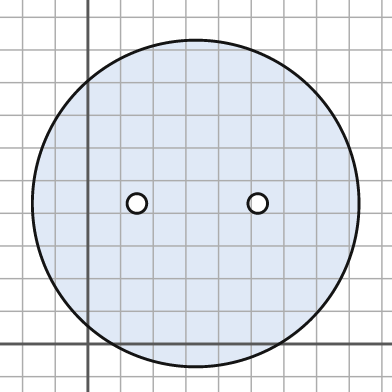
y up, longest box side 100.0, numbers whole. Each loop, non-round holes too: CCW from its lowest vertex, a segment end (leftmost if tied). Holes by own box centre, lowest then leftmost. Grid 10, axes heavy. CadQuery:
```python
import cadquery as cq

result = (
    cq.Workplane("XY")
    .moveTo(33.0, 43.0)
    .circle(50.0)
    .moveTo(15.0, 43.0)
    .circle(3.0)
    .moveTo(52.0, 43.0)
    .circle(3.0)
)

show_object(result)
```